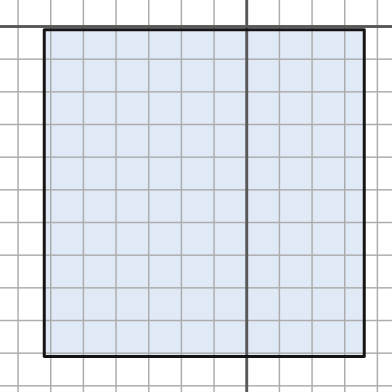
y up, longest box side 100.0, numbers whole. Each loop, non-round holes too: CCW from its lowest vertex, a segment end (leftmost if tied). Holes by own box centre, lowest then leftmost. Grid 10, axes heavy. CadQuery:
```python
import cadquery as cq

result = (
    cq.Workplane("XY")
    .moveTo(-62.0, -101.0)
    .lineTo(36.0, -101.0)
    .lineTo(36.0, -1.0)
    .lineTo(-62.0, -1.0)
    .close()
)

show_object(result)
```